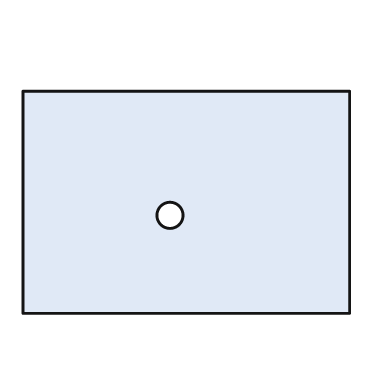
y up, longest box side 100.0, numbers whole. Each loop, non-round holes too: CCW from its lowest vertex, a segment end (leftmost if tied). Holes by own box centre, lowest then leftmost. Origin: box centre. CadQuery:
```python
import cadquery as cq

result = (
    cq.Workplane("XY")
    .moveTo(-50.0, -34.0)
    .lineTo(50.0, -34.0)
    .lineTo(50.0, 34.0)
    .lineTo(-50.0, 34.0)
    .close()
    .moveTo(-5.0, -4.0)
    .circle(4.0)
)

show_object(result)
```